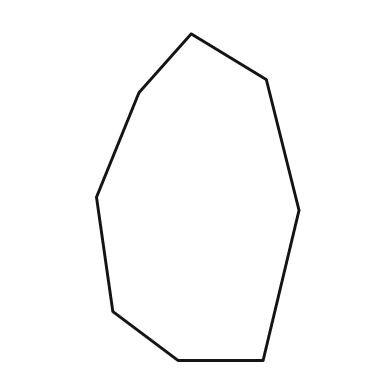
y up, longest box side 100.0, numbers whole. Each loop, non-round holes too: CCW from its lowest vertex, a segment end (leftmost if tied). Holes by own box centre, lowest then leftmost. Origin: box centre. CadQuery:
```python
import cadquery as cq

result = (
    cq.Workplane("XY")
    .moveTo(-6.0, -50.0)
    .lineTo(20.0, -50.0)
    .lineTo(31.0, -4.0)
    .lineTo(21.0, 36.0)
    .lineTo(-2.0, 50.0)
    .lineTo(-18.0, 32.0)
    .lineTo(-31.0, 0.0)
    .lineTo(-26.0, -35.0)
    .close()
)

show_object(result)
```